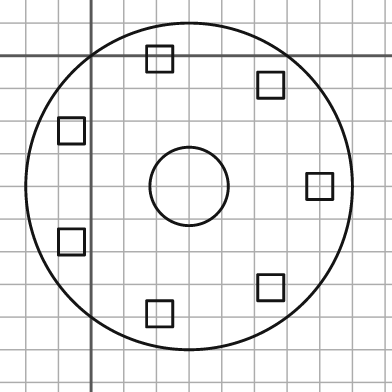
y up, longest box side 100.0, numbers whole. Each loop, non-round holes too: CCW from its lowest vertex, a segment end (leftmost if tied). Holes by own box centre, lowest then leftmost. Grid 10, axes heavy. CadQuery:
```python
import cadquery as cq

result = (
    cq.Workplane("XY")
    .moveTo(30.0, -40.0)
    .circle(50.0)
    .moveTo(17.0, -83.0)
    .lineTo(25.0, -83.0)
    .lineTo(25.0, -75.0)
    .lineTo(17.0, -75.0)
    .close()
    .moveTo(51.0, -75.0)
    .lineTo(59.0, -75.0)
    .lineTo(59.0, -67.0)
    .lineTo(51.0, -67.0)
    .close()
    .moveTo(-10.0, -61.0)
    .lineTo(-2.0, -61.0)
    .lineTo(-2.0, -53.0)
    .lineTo(-10.0, -53.0)
    .close()
    .moveTo(30.0, -40.0)
    .circle(12.0)
    .moveTo(66.0, -44.0)
    .lineTo(74.0, -44.0)
    .lineTo(74.0, -36.0)
    .lineTo(66.0, -36.0)
    .close()
    .moveTo(-10.0, -27.0)
    .lineTo(-2.0, -27.0)
    .lineTo(-2.0, -19.0)
    .lineTo(-10.0, -19.0)
    .close()
    .moveTo(51.0, -13.0)
    .lineTo(59.0, -13.0)
    .lineTo(59.0, -5.0)
    .lineTo(51.0, -5.0)
    .close()
    .moveTo(17.0, -5.0)
    .lineTo(25.0, -5.0)
    .lineTo(25.0, 3.0)
    .lineTo(17.0, 3.0)
    .close()
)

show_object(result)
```